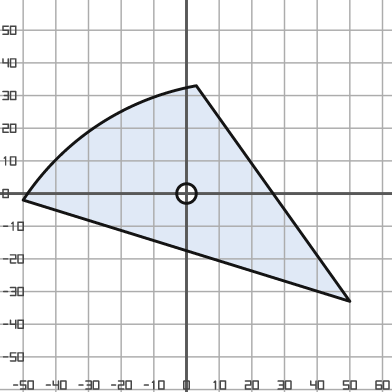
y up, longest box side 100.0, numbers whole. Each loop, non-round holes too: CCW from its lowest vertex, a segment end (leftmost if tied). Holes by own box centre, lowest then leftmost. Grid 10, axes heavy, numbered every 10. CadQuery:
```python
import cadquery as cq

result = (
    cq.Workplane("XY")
    .moveTo(50.0, -33.0)
    .lineTo(3.0, 33.0)
    .threePointArc((-27.0, 21.0), (-50.0, -2.0))
    .close()
    .moveTo(0.0, 0.0)
    .circle(3.0)
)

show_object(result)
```